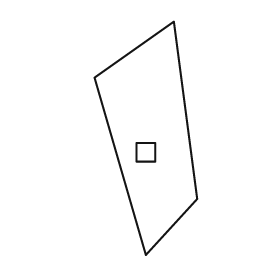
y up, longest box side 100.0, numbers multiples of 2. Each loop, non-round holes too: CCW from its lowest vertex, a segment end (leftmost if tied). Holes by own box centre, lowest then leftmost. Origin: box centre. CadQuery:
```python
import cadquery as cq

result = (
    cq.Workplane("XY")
    .moveTo(0.0, -50.0)
    .lineTo(22.0, -26.0)
    .lineTo(12.0, 50.0)
    .lineTo(-22.0, 26.0)
    .close()
    .moveTo(-4.0, -10.0)
    .lineTo(4.0, -10.0)
    .lineTo(4.0, -2.0)
    .lineTo(-4.0, -2.0)
    .close()
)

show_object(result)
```